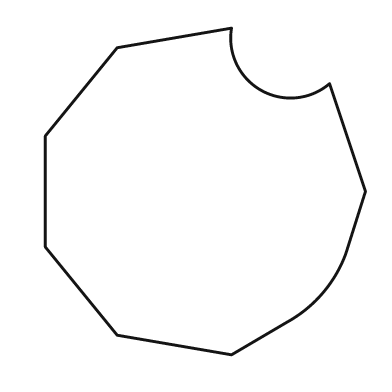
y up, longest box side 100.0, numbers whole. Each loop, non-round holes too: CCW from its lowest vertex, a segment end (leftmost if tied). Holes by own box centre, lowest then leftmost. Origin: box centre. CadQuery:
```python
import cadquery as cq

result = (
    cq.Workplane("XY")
    .moveTo(8.0, -50.0)
    .lineTo(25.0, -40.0)
    .threePointArc((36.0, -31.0), (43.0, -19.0))
    .lineTo(49.0, 0.0)
    .lineTo(38.0, 33.0)
    .threePointArc((17.0, 31.0), (8.0, 50.0))
    .lineTo(-27.0, 44.0)
    .lineTo(-49.0, 17.0)
    .lineTo(-49.0, -17.0)
    .lineTo(-27.0, -44.0)
    .close()
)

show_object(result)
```